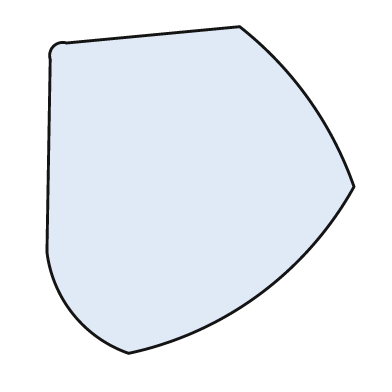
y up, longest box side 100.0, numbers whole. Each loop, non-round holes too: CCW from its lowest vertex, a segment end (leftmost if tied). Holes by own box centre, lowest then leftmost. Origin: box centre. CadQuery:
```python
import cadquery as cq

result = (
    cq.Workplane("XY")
    .moveTo(-22.0, -50.0)
    .threePointArc((18.0, -32.0), (47.0, 1.0))
    .threePointArc((33.0, 28.0), (12.0, 50.0))
    .lineTo(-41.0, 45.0)
    .threePointArc((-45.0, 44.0), (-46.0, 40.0))
    .lineTo(-47.0, -19.0)
    .threePointArc((-39.0, -38.0), (-22.0, -50.0))
    .close()
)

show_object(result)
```